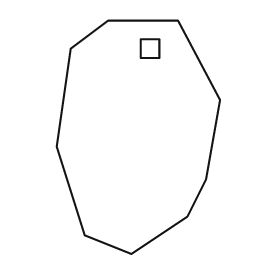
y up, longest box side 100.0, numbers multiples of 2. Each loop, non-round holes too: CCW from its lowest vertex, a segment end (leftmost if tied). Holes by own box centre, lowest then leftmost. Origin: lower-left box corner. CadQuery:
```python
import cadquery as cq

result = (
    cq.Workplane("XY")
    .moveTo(32.0, 0.0)
    .lineTo(56.0, 16.0)
    .lineTo(64.0, 32.0)
    .lineTo(70.0, 66.0)
    .lineTo(52.0, 100.0)
    .lineTo(22.0, 100.0)
    .lineTo(6.0, 88.0)
    .lineTo(0.0, 46.0)
    .lineTo(12.0, 8.0)
    .close()
    .moveTo(36.0, 84.0)
    .lineTo(44.0, 84.0)
    .lineTo(44.0, 92.0)
    .lineTo(36.0, 92.0)
    .close()
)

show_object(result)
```